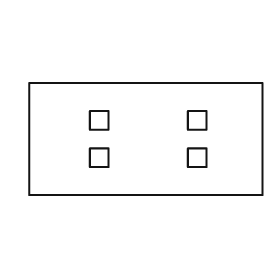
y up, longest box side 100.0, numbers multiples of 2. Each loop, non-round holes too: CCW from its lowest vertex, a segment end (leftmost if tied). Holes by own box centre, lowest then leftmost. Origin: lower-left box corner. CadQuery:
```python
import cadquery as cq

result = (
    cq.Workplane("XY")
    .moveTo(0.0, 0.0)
    .lineTo(100.0, 0.0)
    .lineTo(100.0, 48.0)
    .lineTo(0.0, 48.0)
    .close()
    .moveTo(26.0, 12.0)
    .lineTo(34.0, 12.0)
    .lineTo(34.0, 20.0)
    .lineTo(26.0, 20.0)
    .close()
    .moveTo(68.0, 12.0)
    .lineTo(76.0, 12.0)
    .lineTo(76.0, 20.0)
    .lineTo(68.0, 20.0)
    .close()
    .moveTo(26.0, 28.0)
    .lineTo(34.0, 28.0)
    .lineTo(34.0, 36.0)
    .lineTo(26.0, 36.0)
    .close()
    .moveTo(68.0, 28.0)
    .lineTo(76.0, 28.0)
    .lineTo(76.0, 36.0)
    .lineTo(68.0, 36.0)
    .close()
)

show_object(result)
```